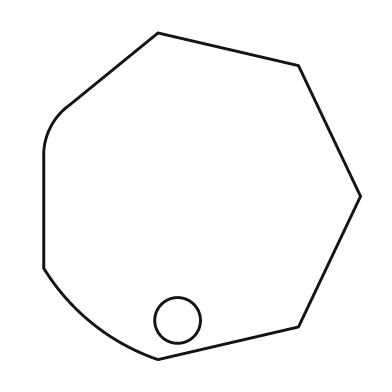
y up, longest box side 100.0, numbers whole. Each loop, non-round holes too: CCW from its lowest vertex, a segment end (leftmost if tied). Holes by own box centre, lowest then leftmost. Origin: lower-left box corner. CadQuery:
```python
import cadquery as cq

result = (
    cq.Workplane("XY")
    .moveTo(35.0, 0.0)
    .lineTo(78.0, 10.0)
    .lineTo(97.0, 50.0)
    .lineTo(78.0, 90.0)
    .lineTo(35.0, 100.0)
    .lineTo(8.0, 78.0)
    .threePointArc((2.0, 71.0), (0.0, 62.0))
    .lineTo(0.0, 28.0)
    .threePointArc((15.0, 11.0), (35.0, 0.0))
    .close()
    .moveTo(41.0, 12.0)
    .circle(7.0)
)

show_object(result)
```